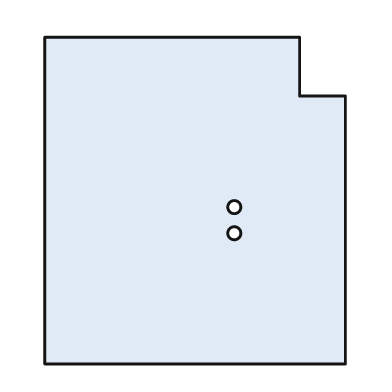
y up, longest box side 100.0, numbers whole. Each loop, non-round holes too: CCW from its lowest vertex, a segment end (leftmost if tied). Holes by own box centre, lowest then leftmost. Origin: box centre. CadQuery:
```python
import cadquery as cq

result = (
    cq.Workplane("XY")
    .moveTo(-46.0, -50.0)
    .lineTo(46.0, -50.0)
    .lineTo(46.0, 32.0)
    .lineTo(32.0, 32.0)
    .lineTo(32.0, 50.0)
    .lineTo(-46.0, 50.0)
    .close()
    .moveTo(12.0, -10.0)
    .circle(2.0)
    .moveTo(12.0, -2.0)
    .circle(2.0)
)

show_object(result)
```